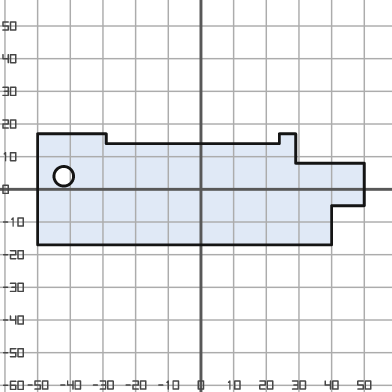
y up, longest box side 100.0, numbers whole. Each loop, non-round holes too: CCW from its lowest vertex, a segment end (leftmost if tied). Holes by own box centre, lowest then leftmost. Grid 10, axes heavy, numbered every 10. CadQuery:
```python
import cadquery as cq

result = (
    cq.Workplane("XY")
    .moveTo(-50.0, -17.0)
    .lineTo(40.0, -17.0)
    .lineTo(40.0, -5.0)
    .lineTo(50.0, -5.0)
    .lineTo(50.0, 8.0)
    .lineTo(29.0, 8.0)
    .lineTo(29.0, 17.0)
    .lineTo(24.0, 17.0)
    .lineTo(24.0, 14.0)
    .lineTo(-29.0, 14.0)
    .lineTo(-29.0, 17.0)
    .lineTo(-50.0, 17.0)
    .close()
    .moveTo(-42.0, 4.0)
    .circle(3.0)
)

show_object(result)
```